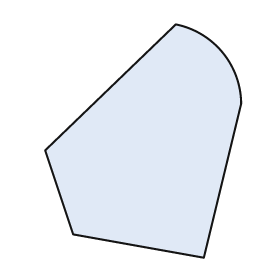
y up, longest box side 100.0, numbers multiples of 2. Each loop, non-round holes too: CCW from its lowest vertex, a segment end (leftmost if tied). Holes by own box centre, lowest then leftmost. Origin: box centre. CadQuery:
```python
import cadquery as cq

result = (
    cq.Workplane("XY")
    .moveTo(26.0, -50.0)
    .lineTo(42.0, 16.0)
    .threePointArc((34.0, 38.0), (14.0, 50.0))
    .lineTo(-42.0, -4.0)
    .lineTo(-30.0, -40.0)
    .close()
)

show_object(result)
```